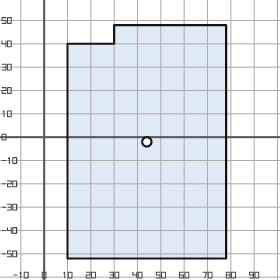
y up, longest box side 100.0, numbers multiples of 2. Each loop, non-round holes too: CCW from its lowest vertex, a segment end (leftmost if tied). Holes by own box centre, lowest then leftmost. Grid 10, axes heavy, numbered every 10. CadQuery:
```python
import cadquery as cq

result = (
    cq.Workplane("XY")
    .moveTo(10.0, -52.0)
    .lineTo(78.0, -52.0)
    .lineTo(78.0, 48.0)
    .lineTo(30.0, 48.0)
    .lineTo(30.0, 40.0)
    .lineTo(10.0, 40.0)
    .close()
    .moveTo(44.0, -2.0)
    .circle(2.0)
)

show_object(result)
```